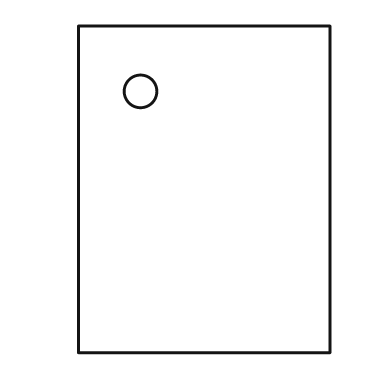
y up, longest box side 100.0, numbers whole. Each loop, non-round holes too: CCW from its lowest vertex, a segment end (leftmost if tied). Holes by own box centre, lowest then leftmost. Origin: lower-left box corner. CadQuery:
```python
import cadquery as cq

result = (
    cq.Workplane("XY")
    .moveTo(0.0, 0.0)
    .lineTo(77.0, 0.0)
    .lineTo(77.0, 100.0)
    .lineTo(0.0, 100.0)
    .close()
    .moveTo(19.0, 80.0)
    .circle(5.0)
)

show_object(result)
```